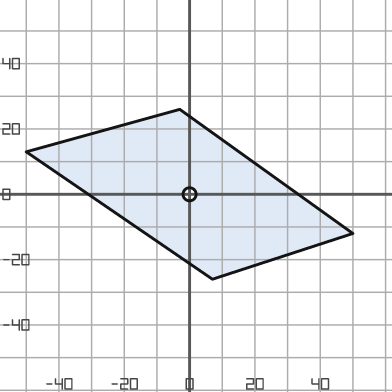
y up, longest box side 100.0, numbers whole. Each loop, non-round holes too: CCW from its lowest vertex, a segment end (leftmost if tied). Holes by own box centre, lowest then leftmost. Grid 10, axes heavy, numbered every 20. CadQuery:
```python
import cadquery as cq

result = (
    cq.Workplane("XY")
    .moveTo(7.0, -26.0)
    .lineTo(50.0, -12.0)
    .lineTo(-3.0, 26.0)
    .lineTo(-50.0, 13.0)
    .close()
    .moveTo(0.0, 0.0)
    .circle(2.0)
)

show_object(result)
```